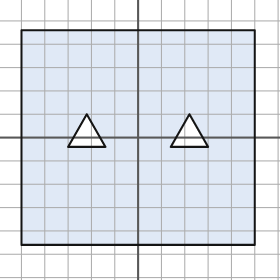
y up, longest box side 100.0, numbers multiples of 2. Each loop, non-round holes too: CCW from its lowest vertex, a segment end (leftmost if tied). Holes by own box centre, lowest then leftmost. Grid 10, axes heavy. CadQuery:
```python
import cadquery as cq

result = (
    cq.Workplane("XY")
    .moveTo(-50.0, -46.0)
    .lineTo(50.0, -46.0)
    .lineTo(50.0, 46.0)
    .lineTo(-50.0, 46.0)
    .close()
    .moveTo(-30.0, -4.0)
    .lineTo(-14.0, -4.0)
    .lineTo(-22.0, 10.0)
    .close()
    .moveTo(14.0, -4.0)
    .lineTo(30.0, -4.0)
    .lineTo(22.0, 10.0)
    .close()
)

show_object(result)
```